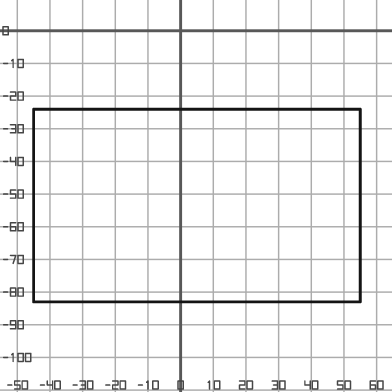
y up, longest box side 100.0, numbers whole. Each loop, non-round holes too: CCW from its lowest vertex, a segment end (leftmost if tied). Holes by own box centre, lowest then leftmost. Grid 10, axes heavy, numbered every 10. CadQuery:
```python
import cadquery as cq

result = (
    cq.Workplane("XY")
    .moveTo(-45.0, -83.0)
    .lineTo(55.0, -83.0)
    .lineTo(55.0, -24.0)
    .lineTo(-45.0, -24.0)
    .close()
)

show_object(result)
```